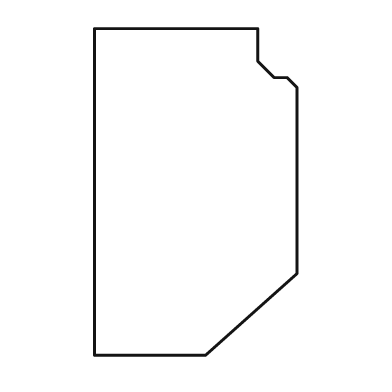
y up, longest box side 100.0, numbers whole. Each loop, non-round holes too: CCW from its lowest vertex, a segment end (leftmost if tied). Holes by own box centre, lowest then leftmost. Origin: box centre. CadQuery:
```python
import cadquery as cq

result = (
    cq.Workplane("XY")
    .moveTo(-31.0, -50.0)
    .lineTo(3.0, -50.0)
    .lineTo(31.0, -25.0)
    .lineTo(31.0, 32.0)
    .lineTo(28.0, 35.0)
    .lineTo(24.0, 35.0)
    .lineTo(19.0, 40.0)
    .lineTo(19.0, 50.0)
    .lineTo(-31.0, 50.0)
    .close()
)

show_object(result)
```